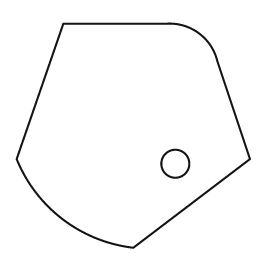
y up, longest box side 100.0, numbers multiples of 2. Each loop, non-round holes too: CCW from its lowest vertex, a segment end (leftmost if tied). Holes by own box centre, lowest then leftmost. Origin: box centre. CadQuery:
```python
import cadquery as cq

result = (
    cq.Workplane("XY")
    .moveTo(0.0, -48.0)
    .lineTo(50.0, -10.0)
    .lineTo(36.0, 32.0)
    .threePointArc((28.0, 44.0), (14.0, 48.0))
    .lineTo(-30.0, 48.0)
    .lineTo(-50.0, -10.0)
    .threePointArc((-30.0, -36.0), (0.0, -48.0))
    .close()
    .moveTo(18.0, -12.0)
    .circle(6.0)
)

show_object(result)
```